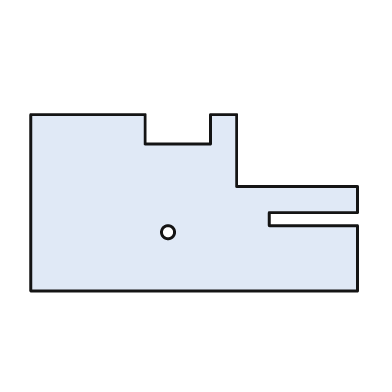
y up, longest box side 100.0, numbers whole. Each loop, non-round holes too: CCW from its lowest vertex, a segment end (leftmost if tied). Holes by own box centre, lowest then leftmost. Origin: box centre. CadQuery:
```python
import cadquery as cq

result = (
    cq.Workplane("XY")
    .moveTo(-50.0, -27.0)
    .lineTo(50.0, -27.0)
    .lineTo(50.0, -7.0)
    .lineTo(23.0, -7.0)
    .lineTo(23.0, -3.0)
    .lineTo(50.0, -3.0)
    .lineTo(50.0, 5.0)
    .lineTo(13.0, 5.0)
    .lineTo(13.0, 27.0)
    .lineTo(5.0, 27.0)
    .lineTo(5.0, 18.0)
    .lineTo(-15.0, 18.0)
    .lineTo(-15.0, 27.0)
    .lineTo(-50.0, 27.0)
    .close()
    .moveTo(-8.0, -9.0)
    .circle(2.0)
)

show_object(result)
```